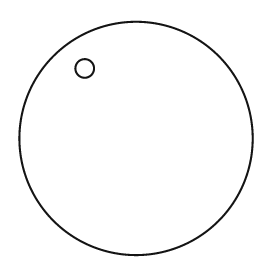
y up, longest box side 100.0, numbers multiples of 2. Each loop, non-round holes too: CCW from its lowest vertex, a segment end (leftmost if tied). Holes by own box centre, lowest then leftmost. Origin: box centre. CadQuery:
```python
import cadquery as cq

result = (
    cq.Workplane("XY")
    .moveTo(0.0, 0.0)
    .circle(50.0)
    .moveTo(-22.0, 30.0)
    .circle(4.0)
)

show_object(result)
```